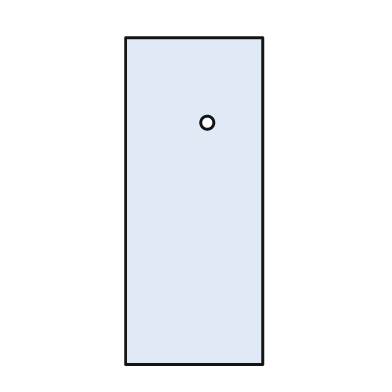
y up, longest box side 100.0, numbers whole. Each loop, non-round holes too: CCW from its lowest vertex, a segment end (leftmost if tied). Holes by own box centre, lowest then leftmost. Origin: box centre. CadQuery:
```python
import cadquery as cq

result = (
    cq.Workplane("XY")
    .moveTo(-21.0, -50.0)
    .lineTo(21.0, -50.0)
    .lineTo(21.0, 50.0)
    .lineTo(-21.0, 50.0)
    .close()
    .moveTo(4.0, 24.0)
    .circle(2.0)
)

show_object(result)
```